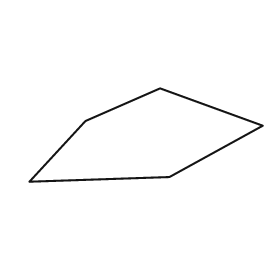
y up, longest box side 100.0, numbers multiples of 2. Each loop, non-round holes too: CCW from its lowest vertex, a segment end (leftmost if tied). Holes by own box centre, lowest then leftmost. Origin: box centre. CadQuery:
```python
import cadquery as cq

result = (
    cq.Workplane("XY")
    .moveTo(-50.0, -20.0)
    .lineTo(10.0, -18.0)
    .lineTo(50.0, 4.0)
    .lineTo(6.0, 20.0)
    .lineTo(-26.0, 6.0)
    .close()
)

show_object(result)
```